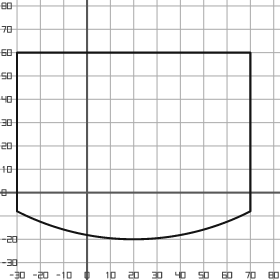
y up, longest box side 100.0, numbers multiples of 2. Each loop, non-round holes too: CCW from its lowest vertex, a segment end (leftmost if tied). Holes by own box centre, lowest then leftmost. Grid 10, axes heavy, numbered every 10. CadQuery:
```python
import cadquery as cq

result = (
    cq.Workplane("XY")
    .moveTo(-30.0, -8.0)
    .threePointArc((20.0, -20.0), (70.0, -8.0))
    .lineTo(70.0, 60.0)
    .lineTo(-30.0, 60.0)
    .close()
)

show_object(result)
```